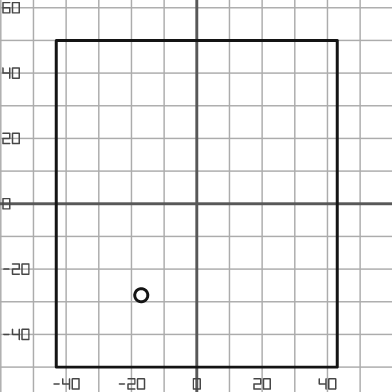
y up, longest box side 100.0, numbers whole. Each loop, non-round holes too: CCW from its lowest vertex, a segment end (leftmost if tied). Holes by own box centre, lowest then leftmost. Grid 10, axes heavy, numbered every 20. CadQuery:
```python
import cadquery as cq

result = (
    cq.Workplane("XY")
    .moveTo(-43.0, -50.0)
    .lineTo(43.0, -50.0)
    .lineTo(43.0, 50.0)
    .lineTo(-43.0, 50.0)
    .close()
    .moveTo(-17.0, -28.0)
    .circle(2.0)
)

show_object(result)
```